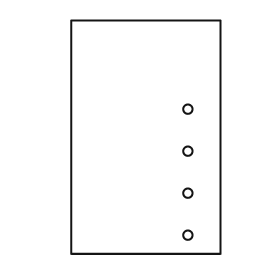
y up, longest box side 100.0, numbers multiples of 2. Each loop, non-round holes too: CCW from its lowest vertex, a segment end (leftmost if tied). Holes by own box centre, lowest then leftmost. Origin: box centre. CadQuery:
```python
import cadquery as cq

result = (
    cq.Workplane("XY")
    .moveTo(-32.0, -50.0)
    .lineTo(32.0, -50.0)
    .lineTo(32.0, 50.0)
    .lineTo(-32.0, 50.0)
    .close()
    .moveTo(18.0, -42.0)
    .circle(2.0)
    .moveTo(18.0, -24.0)
    .circle(2.0)
    .moveTo(18.0, -6.0)
    .circle(2.0)
    .moveTo(18.0, 12.0)
    .circle(2.0)
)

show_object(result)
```